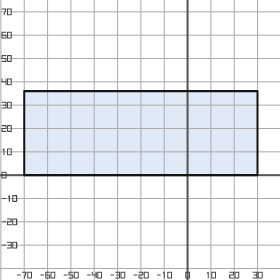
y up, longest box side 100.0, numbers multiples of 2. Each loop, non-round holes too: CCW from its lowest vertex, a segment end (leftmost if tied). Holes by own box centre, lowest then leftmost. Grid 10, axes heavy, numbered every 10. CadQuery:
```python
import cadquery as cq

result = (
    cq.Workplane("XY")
    .moveTo(-70.0, 0.0)
    .lineTo(30.0, 0.0)
    .lineTo(30.0, 36.0)
    .lineTo(-70.0, 36.0)
    .close()
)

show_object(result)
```